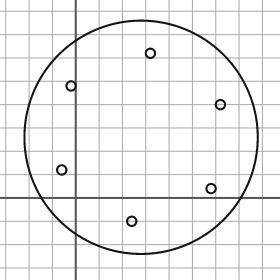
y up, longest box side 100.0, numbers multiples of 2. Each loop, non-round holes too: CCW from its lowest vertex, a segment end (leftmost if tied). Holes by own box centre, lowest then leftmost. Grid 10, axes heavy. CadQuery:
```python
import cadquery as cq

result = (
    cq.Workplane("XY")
    .moveTo(28.0, 26.0)
    .circle(50.0)
    .moveTo(24.0, -10.0)
    .circle(2.0)
    .moveTo(58.0, 4.0)
    .circle(2.0)
    .moveTo(-6.0, 12.0)
    .circle(2.0)
    .moveTo(62.0, 40.0)
    .circle(2.0)
    .moveTo(-2.0, 48.0)
    .circle(2.0)
    .moveTo(32.0, 62.0)
    .circle(2.0)
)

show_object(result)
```